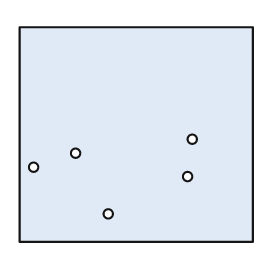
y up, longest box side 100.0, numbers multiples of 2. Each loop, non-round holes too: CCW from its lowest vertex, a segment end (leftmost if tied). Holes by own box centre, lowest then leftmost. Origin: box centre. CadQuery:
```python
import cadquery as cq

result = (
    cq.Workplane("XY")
    .moveTo(-50.0, -46.0)
    .lineTo(50.0, -46.0)
    .lineTo(50.0, 46.0)
    .lineTo(-50.0, 46.0)
    .close()
    .moveTo(-12.0, -34.0)
    .circle(2.0)
    .moveTo(22.0, -18.0)
    .circle(2.0)
    .moveTo(-44.0, -14.0)
    .circle(2.0)
    .moveTo(-26.0, -8.0)
    .circle(2.0)
    .moveTo(24.0, -2.0)
    .circle(2.0)
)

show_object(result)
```